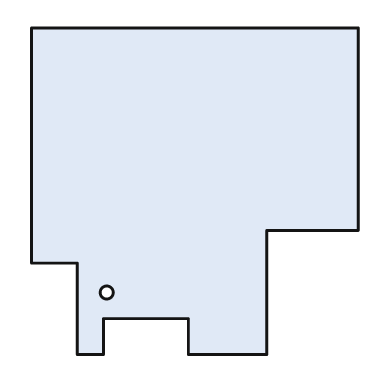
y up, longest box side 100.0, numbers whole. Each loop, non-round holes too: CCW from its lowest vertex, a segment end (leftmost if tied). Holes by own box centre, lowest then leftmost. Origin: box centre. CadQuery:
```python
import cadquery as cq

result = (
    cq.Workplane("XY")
    .moveTo(-36.0, -50.0)
    .lineTo(-28.0, -50.0)
    .lineTo(-28.0, -39.0)
    .lineTo(-2.0, -39.0)
    .lineTo(-2.0, -50.0)
    .lineTo(22.0, -50.0)
    .lineTo(22.0, -12.0)
    .lineTo(50.0, -12.0)
    .lineTo(50.0, 50.0)
    .lineTo(-50.0, 50.0)
    .lineTo(-50.0, -22.0)
    .lineTo(-36.0, -22.0)
    .close()
    .moveTo(-27.0, -31.0)
    .circle(2.0)
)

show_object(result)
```